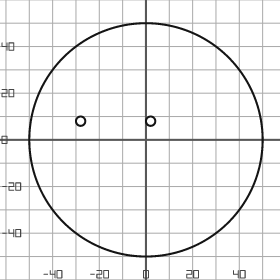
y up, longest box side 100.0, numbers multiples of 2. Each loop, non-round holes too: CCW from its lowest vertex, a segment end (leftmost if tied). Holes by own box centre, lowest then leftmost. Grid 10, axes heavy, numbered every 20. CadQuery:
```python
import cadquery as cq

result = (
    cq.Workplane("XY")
    .moveTo(0.0, 0.0)
    .circle(50.0)
    .moveTo(-28.0, 8.0)
    .circle(2.0)
    .moveTo(2.0, 8.0)
    .circle(2.0)
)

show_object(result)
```